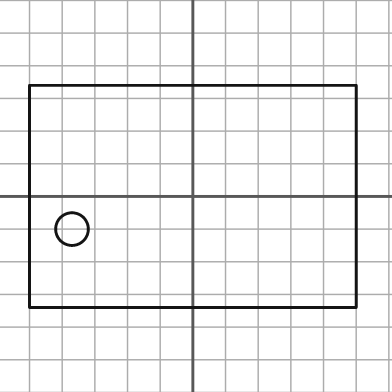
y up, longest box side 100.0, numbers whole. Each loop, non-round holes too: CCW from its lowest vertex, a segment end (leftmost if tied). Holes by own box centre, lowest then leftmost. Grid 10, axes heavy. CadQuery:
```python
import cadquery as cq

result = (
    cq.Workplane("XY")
    .moveTo(-50.0, -34.0)
    .lineTo(50.0, -34.0)
    .lineTo(50.0, 34.0)
    .lineTo(-50.0, 34.0)
    .close()
    .moveTo(-37.0, -10.0)
    .circle(5.0)
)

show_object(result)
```